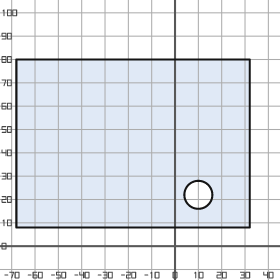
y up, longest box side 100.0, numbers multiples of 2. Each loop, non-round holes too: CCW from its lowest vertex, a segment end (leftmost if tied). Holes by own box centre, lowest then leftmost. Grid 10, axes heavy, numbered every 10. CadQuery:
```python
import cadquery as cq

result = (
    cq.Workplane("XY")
    .moveTo(-68.0, 8.0)
    .lineTo(32.0, 8.0)
    .lineTo(32.0, 80.0)
    .lineTo(-68.0, 80.0)
    .close()
    .moveTo(10.0, 22.0)
    .circle(6.0)
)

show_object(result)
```